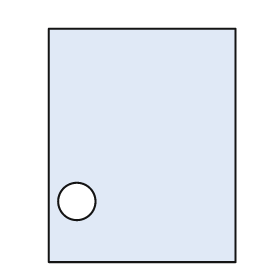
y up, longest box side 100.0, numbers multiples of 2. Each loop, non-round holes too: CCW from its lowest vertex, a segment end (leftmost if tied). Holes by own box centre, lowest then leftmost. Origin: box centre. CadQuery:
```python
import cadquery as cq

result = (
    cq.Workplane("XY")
    .moveTo(-40.0, -50.0)
    .lineTo(40.0, -50.0)
    .lineTo(40.0, 50.0)
    .lineTo(-40.0, 50.0)
    .close()
    .moveTo(-28.0, -24.0)
    .circle(8.0)
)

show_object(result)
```